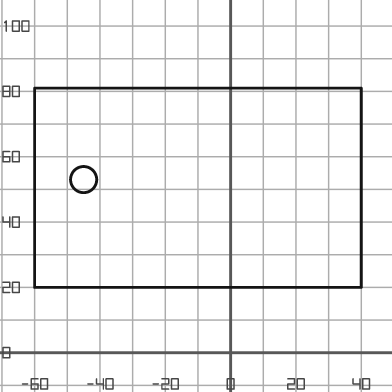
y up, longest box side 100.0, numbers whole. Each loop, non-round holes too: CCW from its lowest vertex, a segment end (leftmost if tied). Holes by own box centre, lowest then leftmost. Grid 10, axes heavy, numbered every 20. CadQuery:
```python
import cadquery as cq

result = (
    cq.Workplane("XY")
    .moveTo(-60.0, 20.0)
    .lineTo(40.0, 20.0)
    .lineTo(40.0, 81.0)
    .lineTo(-60.0, 81.0)
    .close()
    .moveTo(-45.0, 53.0)
    .circle(4.0)
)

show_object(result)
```